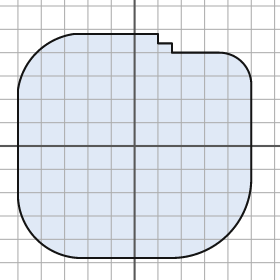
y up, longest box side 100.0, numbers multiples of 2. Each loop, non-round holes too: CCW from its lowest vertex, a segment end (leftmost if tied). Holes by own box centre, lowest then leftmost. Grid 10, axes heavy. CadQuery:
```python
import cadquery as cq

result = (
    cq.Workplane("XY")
    .moveTo(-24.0, -48.0)
    .lineTo(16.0, -48.0)
    .threePointArc((40.0, -38.0), (50.0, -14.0))
    .lineTo(50.0, 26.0)
    .threePointArc((46.0, 36.0), (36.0, 40.0))
    .lineTo(16.0, 40.0)
    .lineTo(16.0, 44.0)
    .lineTo(10.0, 44.0)
    .lineTo(10.0, 48.0)
    .lineTo(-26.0, 48.0)
    .threePointArc((-42.0, 40.0), (-50.0, 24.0))
    .lineTo(-50.0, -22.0)
    .threePointArc((-42.0, -40.0), (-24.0, -48.0))
    .close()
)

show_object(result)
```